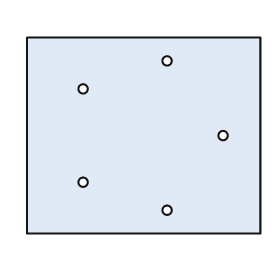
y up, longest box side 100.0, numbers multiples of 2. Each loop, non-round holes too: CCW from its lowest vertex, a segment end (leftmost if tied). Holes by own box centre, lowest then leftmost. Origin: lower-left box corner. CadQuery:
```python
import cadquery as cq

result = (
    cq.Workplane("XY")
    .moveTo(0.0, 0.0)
    .lineTo(100.0, 0.0)
    .lineTo(100.0, 84.0)
    .lineTo(0.0, 84.0)
    .close()
    .moveTo(60.0, 10.0)
    .circle(2.0)
    .moveTo(24.0, 22.0)
    .circle(2.0)
    .moveTo(84.0, 42.0)
    .circle(2.0)
    .moveTo(24.0, 62.0)
    .circle(2.0)
    .moveTo(60.0, 74.0)
    .circle(2.0)
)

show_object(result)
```